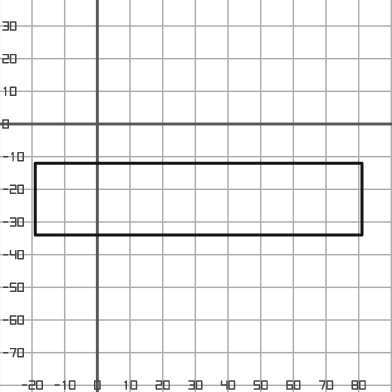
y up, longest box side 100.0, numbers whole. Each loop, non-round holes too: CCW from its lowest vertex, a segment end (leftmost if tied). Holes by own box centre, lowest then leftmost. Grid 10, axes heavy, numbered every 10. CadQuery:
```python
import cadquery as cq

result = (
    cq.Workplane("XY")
    .moveTo(-19.0, -34.0)
    .lineTo(81.0, -34.0)
    .lineTo(81.0, -12.0)
    .lineTo(-19.0, -12.0)
    .close()
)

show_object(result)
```